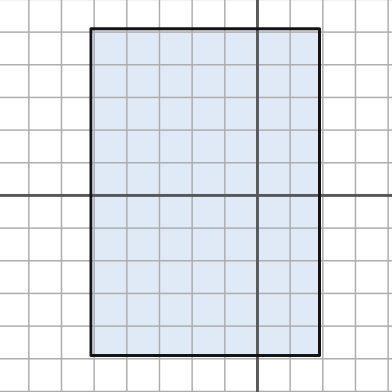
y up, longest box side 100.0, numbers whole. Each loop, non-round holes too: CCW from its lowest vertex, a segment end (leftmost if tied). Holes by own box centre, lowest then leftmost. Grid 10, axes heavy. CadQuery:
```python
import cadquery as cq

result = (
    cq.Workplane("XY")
    .moveTo(-51.0, -49.0)
    .lineTo(19.0, -49.0)
    .lineTo(19.0, 51.0)
    .lineTo(-51.0, 51.0)
    .close()
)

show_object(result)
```